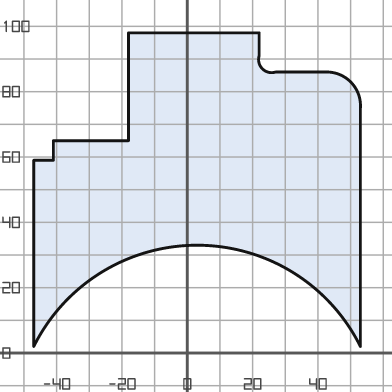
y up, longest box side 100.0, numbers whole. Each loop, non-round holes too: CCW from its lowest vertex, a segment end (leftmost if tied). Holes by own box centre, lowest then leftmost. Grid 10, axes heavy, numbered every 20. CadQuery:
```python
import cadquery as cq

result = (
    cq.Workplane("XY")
    .moveTo(-47.0, 2.0)
    .threePointArc((3.0, 33.0), (53.0, 2.0))
    .lineTo(53.0, 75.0)
    .threePointArc((50.0, 83.0), (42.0, 86.0))
    .lineTo(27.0, 86.0)
    .threePointArc((23.0, 87.0), (22.0, 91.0))
    .lineTo(22.0, 98.0)
    .lineTo(-18.0, 98.0)
    .lineTo(-18.0, 65.0)
    .lineTo(-41.0, 65.0)
    .lineTo(-41.0, 59.0)
    .lineTo(-47.0, 59.0)
    .close()
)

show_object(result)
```